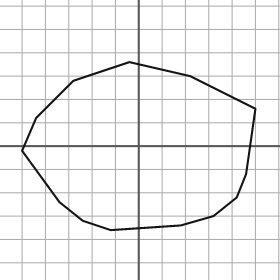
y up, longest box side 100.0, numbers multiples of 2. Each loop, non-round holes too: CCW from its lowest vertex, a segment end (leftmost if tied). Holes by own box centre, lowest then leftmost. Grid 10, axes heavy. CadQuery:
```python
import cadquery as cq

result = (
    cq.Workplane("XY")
    .moveTo(-12.0, -36.0)
    .lineTo(18.0, -34.0)
    .lineTo(32.0, -30.0)
    .lineTo(42.0, -22.0)
    .lineTo(46.0, -12.0)
    .lineTo(50.0, 16.0)
    .lineTo(22.0, 30.0)
    .lineTo(-4.0, 36.0)
    .lineTo(-28.0, 28.0)
    .lineTo(-44.0, 12.0)
    .lineTo(-50.0, -2.0)
    .lineTo(-34.0, -24.0)
    .lineTo(-24.0, -32.0)
    .close()
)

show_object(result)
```